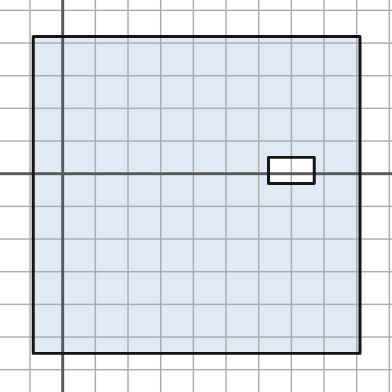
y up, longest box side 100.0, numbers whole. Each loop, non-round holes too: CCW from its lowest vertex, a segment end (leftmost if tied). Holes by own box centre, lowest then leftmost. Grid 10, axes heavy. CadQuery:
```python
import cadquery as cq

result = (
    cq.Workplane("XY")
    .moveTo(-9.0, -55.0)
    .lineTo(91.0, -55.0)
    .lineTo(91.0, 42.0)
    .lineTo(-9.0, 42.0)
    .close()
    .moveTo(63.0, -3.0)
    .lineTo(77.0, -3.0)
    .lineTo(77.0, 5.0)
    .lineTo(63.0, 5.0)
    .close()
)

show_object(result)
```